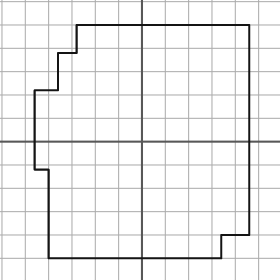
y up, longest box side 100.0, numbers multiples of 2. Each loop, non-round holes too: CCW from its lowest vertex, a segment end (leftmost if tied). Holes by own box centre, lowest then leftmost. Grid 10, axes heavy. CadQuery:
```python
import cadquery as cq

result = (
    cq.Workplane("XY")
    .moveTo(-40.0, -50.0)
    .lineTo(34.0, -50.0)
    .lineTo(34.0, -40.0)
    .lineTo(46.0, -40.0)
    .lineTo(46.0, 50.0)
    .lineTo(-28.0, 50.0)
    .lineTo(-28.0, 38.0)
    .lineTo(-36.0, 38.0)
    .lineTo(-36.0, 22.0)
    .lineTo(-46.0, 22.0)
    .lineTo(-46.0, -12.0)
    .lineTo(-40.0, -12.0)
    .close()
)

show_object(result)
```